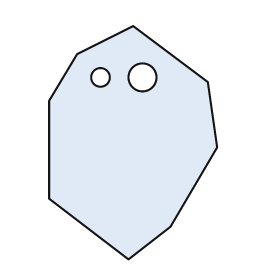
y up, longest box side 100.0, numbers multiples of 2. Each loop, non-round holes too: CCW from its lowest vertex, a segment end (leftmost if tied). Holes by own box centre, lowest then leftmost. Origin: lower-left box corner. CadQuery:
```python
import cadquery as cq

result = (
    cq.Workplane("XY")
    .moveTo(34.0, 0.0)
    .lineTo(52.0, 14.0)
    .lineTo(72.0, 48.0)
    .lineTo(68.0, 76.0)
    .lineTo(36.0, 100.0)
    .lineTo(12.0, 88.0)
    .lineTo(0.0, 68.0)
    .lineTo(0.0, 26.0)
    .close()
    .moveTo(22.0, 78.0)
    .circle(4.0)
    .moveTo(40.0, 78.0)
    .circle(6.0)
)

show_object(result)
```